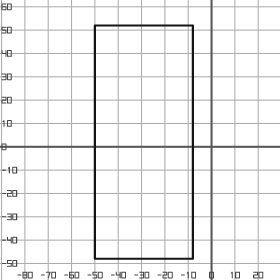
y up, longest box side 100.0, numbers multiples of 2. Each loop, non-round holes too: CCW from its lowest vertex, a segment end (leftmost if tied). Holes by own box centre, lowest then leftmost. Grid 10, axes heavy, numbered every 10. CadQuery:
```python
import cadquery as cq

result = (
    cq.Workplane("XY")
    .moveTo(-50.0, -48.0)
    .lineTo(-8.0, -48.0)
    .lineTo(-8.0, 52.0)
    .lineTo(-50.0, 52.0)
    .close()
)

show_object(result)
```